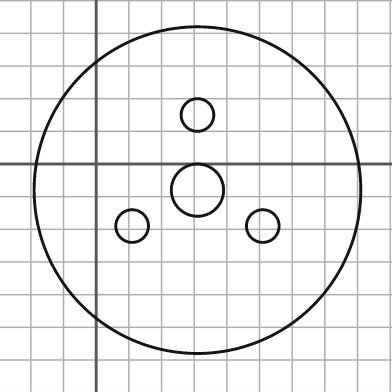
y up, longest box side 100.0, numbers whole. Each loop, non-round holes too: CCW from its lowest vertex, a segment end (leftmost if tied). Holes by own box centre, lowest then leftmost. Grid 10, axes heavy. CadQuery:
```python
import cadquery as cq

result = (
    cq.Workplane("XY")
    .moveTo(31.0, -8.0)
    .circle(50.0)
    .moveTo(11.0, -19.0)
    .circle(5.0)
    .moveTo(51.0, -19.0)
    .circle(5.0)
    .moveTo(31.0, -8.0)
    .circle(8.0)
    .moveTo(31.0, 15.0)
    .circle(5.0)
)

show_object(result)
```